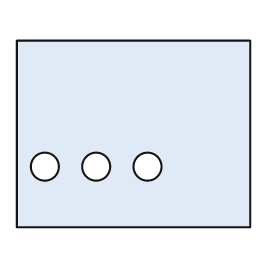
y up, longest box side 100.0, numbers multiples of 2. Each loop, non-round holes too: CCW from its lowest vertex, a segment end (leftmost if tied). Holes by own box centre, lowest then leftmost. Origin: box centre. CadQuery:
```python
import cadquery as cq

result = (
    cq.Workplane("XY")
    .moveTo(-50.0, -40.0)
    .lineTo(50.0, -40.0)
    .lineTo(50.0, 40.0)
    .lineTo(-50.0, 40.0)
    .close()
    .moveTo(-38.0, -14.0)
    .circle(6.0)
    .moveTo(-16.0, -14.0)
    .circle(6.0)
    .moveTo(6.0, -14.0)
    .circle(6.0)
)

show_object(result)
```